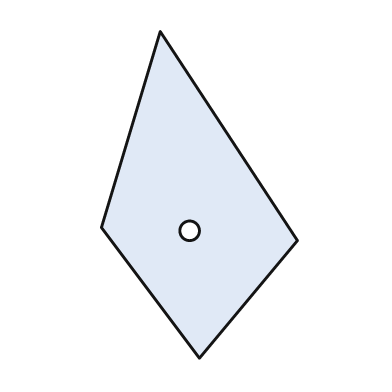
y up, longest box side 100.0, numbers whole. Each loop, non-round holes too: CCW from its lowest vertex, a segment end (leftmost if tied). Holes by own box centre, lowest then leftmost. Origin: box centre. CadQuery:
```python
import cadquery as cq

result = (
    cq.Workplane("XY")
    .moveTo(0.0, -50.0)
    .lineTo(30.0, -14.0)
    .lineTo(-12.0, 50.0)
    .lineTo(-30.0, -10.0)
    .close()
    .moveTo(-3.0, -11.0)
    .circle(3.0)
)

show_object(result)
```